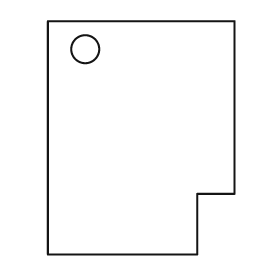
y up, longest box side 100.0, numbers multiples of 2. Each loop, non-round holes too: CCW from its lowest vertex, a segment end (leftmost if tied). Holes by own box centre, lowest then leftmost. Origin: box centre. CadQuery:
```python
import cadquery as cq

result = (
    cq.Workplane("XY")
    .moveTo(-40.0, -50.0)
    .lineTo(24.0, -50.0)
    .lineTo(24.0, -24.0)
    .lineTo(40.0, -24.0)
    .lineTo(40.0, 50.0)
    .lineTo(-40.0, 50.0)
    .close()
    .moveTo(-24.0, 38.0)
    .circle(6.0)
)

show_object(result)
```